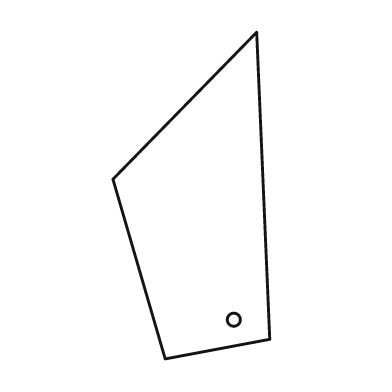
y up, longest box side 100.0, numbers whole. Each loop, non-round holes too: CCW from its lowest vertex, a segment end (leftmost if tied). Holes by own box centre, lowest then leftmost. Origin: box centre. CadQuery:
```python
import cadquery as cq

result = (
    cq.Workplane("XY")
    .moveTo(-8.0, -50.0)
    .lineTo(24.0, -44.0)
    .lineTo(20.0, 50.0)
    .lineTo(-24.0, 5.0)
    .close()
    .moveTo(13.0, -38.0)
    .circle(2.0)
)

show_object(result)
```